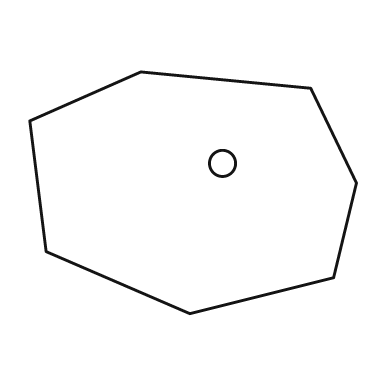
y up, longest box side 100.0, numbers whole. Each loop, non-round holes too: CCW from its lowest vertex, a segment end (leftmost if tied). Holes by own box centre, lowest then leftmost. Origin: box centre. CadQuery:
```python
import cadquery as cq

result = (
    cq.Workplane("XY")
    .moveTo(-1.0, -37.0)
    .lineTo(43.0, -26.0)
    .lineTo(50.0, 3.0)
    .lineTo(36.0, 32.0)
    .lineTo(-16.0, 37.0)
    .lineTo(-50.0, 22.0)
    .lineTo(-45.0, -18.0)
    .close()
    .moveTo(9.0, 9.0)
    .circle(4.0)
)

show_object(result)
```